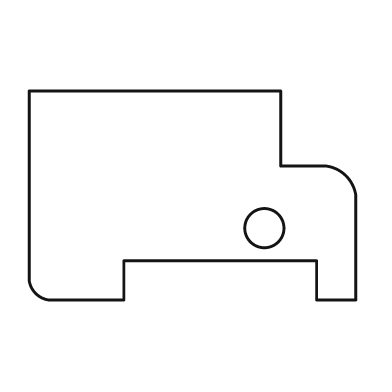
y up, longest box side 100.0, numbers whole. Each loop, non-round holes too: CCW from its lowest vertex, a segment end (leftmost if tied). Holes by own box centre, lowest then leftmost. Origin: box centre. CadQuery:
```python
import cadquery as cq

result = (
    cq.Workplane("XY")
    .moveTo(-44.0, -32.0)
    .lineTo(-21.0, -32.0)
    .lineTo(-21.0, -20.0)
    .lineTo(38.0, -20.0)
    .lineTo(38.0, -32.0)
    .lineTo(50.0, -32.0)
    .lineTo(50.0, 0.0)
    .threePointArc((47.0, 6.0), (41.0, 9.0))
    .lineTo(27.0, 9.0)
    .lineTo(27.0, 32.0)
    .lineTo(-50.0, 32.0)
    .lineTo(-50.0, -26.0)
    .threePointArc((-48.0, -30.0), (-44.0, -32.0))
    .close()
    .moveTo(22.0, -10.0)
    .circle(6.0)
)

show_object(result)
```